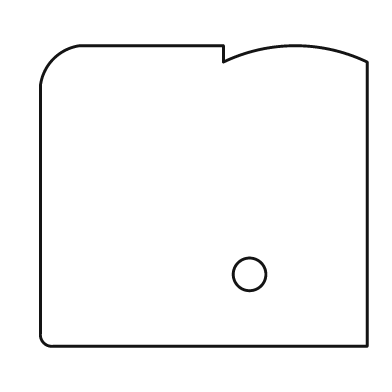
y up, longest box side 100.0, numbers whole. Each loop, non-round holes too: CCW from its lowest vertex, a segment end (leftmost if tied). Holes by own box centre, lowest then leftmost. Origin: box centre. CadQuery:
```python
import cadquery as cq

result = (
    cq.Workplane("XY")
    .moveTo(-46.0, -46.0)
    .lineTo(50.0, -46.0)
    .lineTo(50.0, 41.0)
    .threePointArc((28.0, 46.0), (6.0, 41.0))
    .lineTo(6.0, 46.0)
    .lineTo(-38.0, 46.0)
    .threePointArc((-46.0, 42.0), (-50.0, 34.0))
    .lineTo(-50.0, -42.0)
    .threePointArc((-49.0, -45.0), (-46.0, -46.0))
    .close()
    .moveTo(14.0, -24.0)
    .circle(5.0)
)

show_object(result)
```